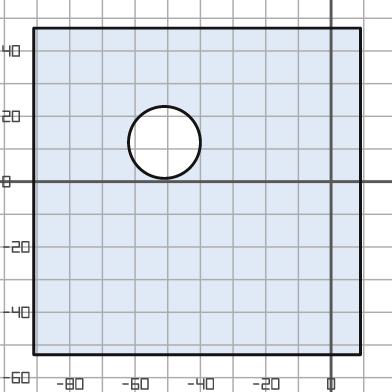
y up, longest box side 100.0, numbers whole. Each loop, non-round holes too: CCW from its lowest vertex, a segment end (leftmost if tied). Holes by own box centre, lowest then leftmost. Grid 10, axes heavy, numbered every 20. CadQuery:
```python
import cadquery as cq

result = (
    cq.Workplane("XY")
    .moveTo(-91.0, -53.0)
    .lineTo(9.0, -53.0)
    .lineTo(9.0, 47.0)
    .lineTo(-91.0, 47.0)
    .close()
    .moveTo(-51.0, 12.0)
    .circle(11.0)
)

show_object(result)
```